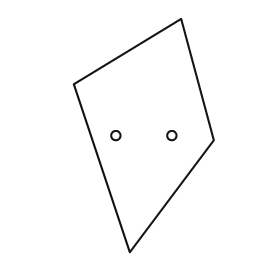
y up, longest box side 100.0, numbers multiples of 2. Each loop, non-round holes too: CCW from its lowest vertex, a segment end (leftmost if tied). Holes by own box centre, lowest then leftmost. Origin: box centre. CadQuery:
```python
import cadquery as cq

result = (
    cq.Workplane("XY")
    .moveTo(-6.0, -50.0)
    .lineTo(30.0, -2.0)
    .lineTo(16.0, 50.0)
    .lineTo(-30.0, 22.0)
    .close()
    .moveTo(-12.0, 0.0)
    .circle(2.0)
    .moveTo(12.0, 0.0)
    .circle(2.0)
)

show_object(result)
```